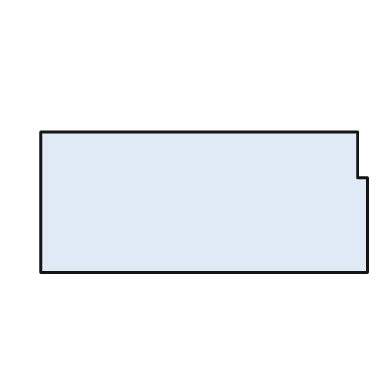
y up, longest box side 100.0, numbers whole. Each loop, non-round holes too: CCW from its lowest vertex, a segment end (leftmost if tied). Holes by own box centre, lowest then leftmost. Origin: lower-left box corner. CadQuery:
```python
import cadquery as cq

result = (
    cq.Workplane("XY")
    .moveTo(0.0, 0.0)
    .lineTo(100.0, 0.0)
    .lineTo(100.0, 29.0)
    .lineTo(97.0, 29.0)
    .lineTo(97.0, 43.0)
    .lineTo(0.0, 43.0)
    .close()
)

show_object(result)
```